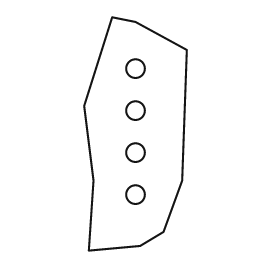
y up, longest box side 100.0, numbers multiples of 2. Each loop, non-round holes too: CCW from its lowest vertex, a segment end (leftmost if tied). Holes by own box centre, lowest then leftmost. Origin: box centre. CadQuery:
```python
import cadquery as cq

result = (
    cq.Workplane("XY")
    .moveTo(-20.0, -50.0)
    .lineTo(2.0, -48.0)
    .lineTo(12.0, -42.0)
    .lineTo(20.0, -20.0)
    .lineTo(22.0, 36.0)
    .lineTo(0.0, 48.0)
    .lineTo(-10.0, 50.0)
    .lineTo(-22.0, 12.0)
    .lineTo(-18.0, -20.0)
    .close()
    .moveTo(0.0, -26.0)
    .circle(4.0)
    .moveTo(0.0, -8.0)
    .circle(4.0)
    .moveTo(0.0, 10.0)
    .circle(4.0)
    .moveTo(0.0, 28.0)
    .circle(4.0)
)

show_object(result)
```